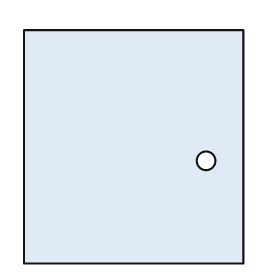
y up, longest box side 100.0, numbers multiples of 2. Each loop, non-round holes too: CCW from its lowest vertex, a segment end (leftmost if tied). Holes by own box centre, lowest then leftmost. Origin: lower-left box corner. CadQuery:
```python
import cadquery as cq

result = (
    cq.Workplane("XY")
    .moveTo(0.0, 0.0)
    .lineTo(94.0, 0.0)
    .lineTo(94.0, 100.0)
    .lineTo(0.0, 100.0)
    .close()
    .moveTo(78.0, 44.0)
    .circle(4.0)
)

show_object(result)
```